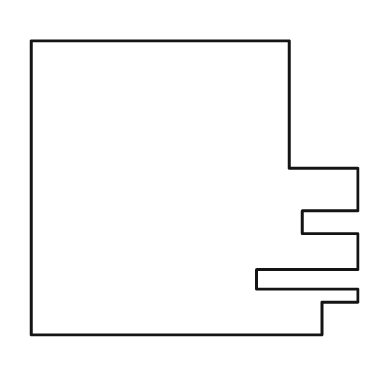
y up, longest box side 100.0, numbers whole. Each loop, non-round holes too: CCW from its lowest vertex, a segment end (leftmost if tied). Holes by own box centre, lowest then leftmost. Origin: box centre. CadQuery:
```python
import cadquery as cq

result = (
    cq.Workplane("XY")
    .moveTo(-50.0, -45.0)
    .lineTo(39.0, -45.0)
    .lineTo(39.0, -35.0)
    .lineTo(50.0, -35.0)
    .lineTo(50.0, -31.0)
    .lineTo(19.0, -31.0)
    .lineTo(19.0, -25.0)
    .lineTo(50.0, -25.0)
    .lineTo(50.0, -14.0)
    .lineTo(33.0, -14.0)
    .lineTo(33.0, -7.0)
    .lineTo(50.0, -7.0)
    .lineTo(50.0, 6.0)
    .lineTo(29.0, 6.0)
    .lineTo(29.0, 45.0)
    .lineTo(-50.0, 45.0)
    .close()
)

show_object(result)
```